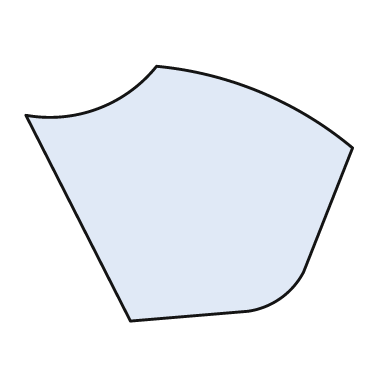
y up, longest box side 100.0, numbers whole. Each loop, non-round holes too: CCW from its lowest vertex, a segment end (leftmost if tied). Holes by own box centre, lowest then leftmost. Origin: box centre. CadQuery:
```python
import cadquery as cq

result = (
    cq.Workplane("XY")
    .moveTo(-18.0, -39.0)
    .lineTo(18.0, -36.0)
    .threePointArc((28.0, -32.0), (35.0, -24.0))
    .lineTo(50.0, 14.0)
    .threePointArc((22.0, 31.0), (-10.0, 39.0))
    .threePointArc((-28.0, 26.0), (-50.0, 24.0))
    .close()
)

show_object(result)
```